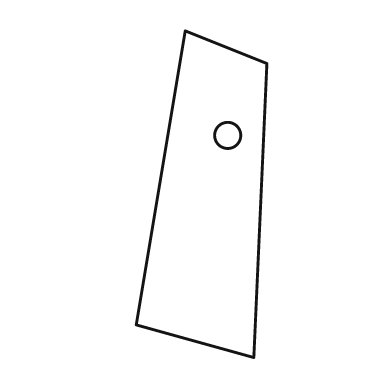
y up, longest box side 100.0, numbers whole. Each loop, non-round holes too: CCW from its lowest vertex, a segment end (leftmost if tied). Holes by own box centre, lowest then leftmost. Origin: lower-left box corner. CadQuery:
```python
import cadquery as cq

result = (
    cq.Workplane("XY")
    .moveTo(36.0, 0.0)
    .lineTo(40.0, 90.0)
    .lineTo(15.0, 100.0)
    .lineTo(0.0, 10.0)
    .close()
    .moveTo(28.0, 68.0)
    .circle(4.0)
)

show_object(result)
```